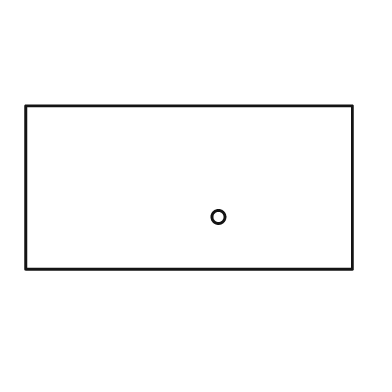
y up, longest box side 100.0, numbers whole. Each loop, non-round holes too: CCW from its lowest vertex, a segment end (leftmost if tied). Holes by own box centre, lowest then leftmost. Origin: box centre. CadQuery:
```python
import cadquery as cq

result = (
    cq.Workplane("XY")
    .moveTo(-50.0, -25.0)
    .lineTo(50.0, -25.0)
    .lineTo(50.0, 25.0)
    .lineTo(-50.0, 25.0)
    .close()
    .moveTo(9.0, -9.0)
    .circle(2.0)
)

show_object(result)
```